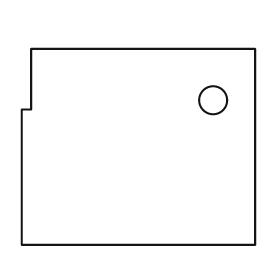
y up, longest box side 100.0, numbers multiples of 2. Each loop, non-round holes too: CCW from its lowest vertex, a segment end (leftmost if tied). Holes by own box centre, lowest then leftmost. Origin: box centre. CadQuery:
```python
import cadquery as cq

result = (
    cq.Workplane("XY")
    .moveTo(-50.0, -42.0)
    .lineTo(50.0, -42.0)
    .lineTo(50.0, 42.0)
    .lineTo(-46.0, 42.0)
    .lineTo(-46.0, 16.0)
    .lineTo(-50.0, 16.0)
    .close()
    .moveTo(32.0, 20.0)
    .circle(6.0)
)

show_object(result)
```